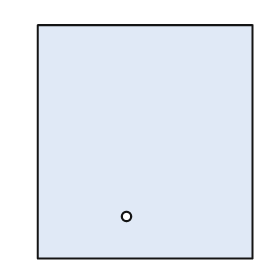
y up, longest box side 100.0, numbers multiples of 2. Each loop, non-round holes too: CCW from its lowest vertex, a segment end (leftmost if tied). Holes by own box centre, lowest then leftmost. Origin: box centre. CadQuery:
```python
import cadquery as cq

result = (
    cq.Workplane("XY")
    .moveTo(-46.0, -50.0)
    .lineTo(46.0, -50.0)
    .lineTo(46.0, 50.0)
    .lineTo(-46.0, 50.0)
    .close()
    .moveTo(-8.0, -32.0)
    .circle(2.0)
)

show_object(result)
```